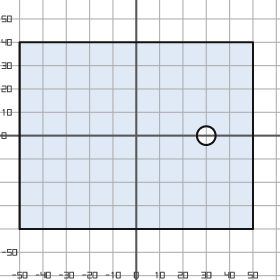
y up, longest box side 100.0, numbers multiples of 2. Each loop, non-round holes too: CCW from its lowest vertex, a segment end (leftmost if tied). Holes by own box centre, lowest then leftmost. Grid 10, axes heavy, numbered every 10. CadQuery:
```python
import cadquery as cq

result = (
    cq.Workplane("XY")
    .moveTo(-50.0, -40.0)
    .lineTo(50.0, -40.0)
    .lineTo(50.0, 40.0)
    .lineTo(-50.0, 40.0)
    .close()
    .moveTo(30.0, 0.0)
    .circle(4.0)
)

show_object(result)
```